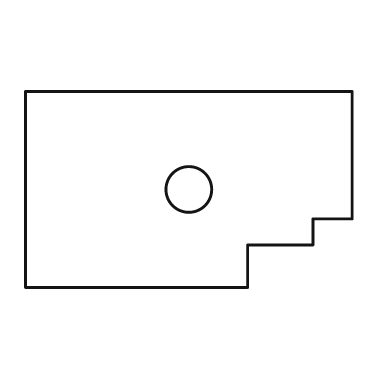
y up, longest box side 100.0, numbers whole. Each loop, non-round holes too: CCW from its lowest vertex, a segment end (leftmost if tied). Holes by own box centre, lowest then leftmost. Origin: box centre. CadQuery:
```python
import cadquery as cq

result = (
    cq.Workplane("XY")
    .moveTo(-50.0, -30.0)
    .lineTo(18.0, -30.0)
    .lineTo(18.0, -17.0)
    .lineTo(38.0, -17.0)
    .lineTo(38.0, -9.0)
    .lineTo(50.0, -9.0)
    .lineTo(50.0, 30.0)
    .lineTo(-50.0, 30.0)
    .close()
    .moveTo(0.0, 0.0)
    .circle(7.0)
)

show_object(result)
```